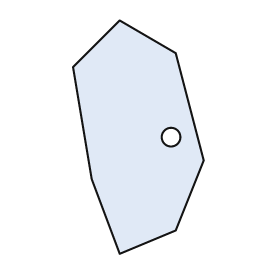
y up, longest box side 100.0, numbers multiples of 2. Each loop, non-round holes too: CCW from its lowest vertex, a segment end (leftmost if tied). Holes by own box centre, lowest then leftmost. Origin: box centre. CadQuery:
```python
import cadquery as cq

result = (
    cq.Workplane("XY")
    .moveTo(-8.0, -50.0)
    .lineTo(16.0, -40.0)
    .lineTo(28.0, -10.0)
    .lineTo(16.0, 36.0)
    .lineTo(-8.0, 50.0)
    .lineTo(-28.0, 30.0)
    .lineTo(-20.0, -18.0)
    .close()
    .moveTo(14.0, 0.0)
    .circle(4.0)
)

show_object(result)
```